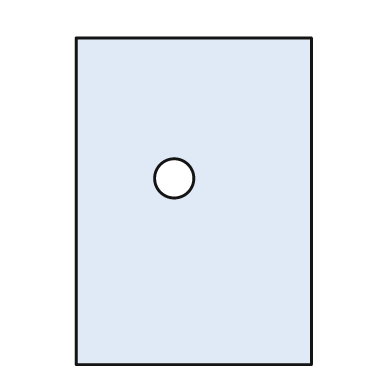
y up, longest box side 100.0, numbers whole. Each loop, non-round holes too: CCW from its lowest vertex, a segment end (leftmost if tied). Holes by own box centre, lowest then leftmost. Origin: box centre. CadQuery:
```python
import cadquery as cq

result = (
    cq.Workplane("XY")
    .moveTo(-36.0, -50.0)
    .lineTo(36.0, -50.0)
    .lineTo(36.0, 50.0)
    .lineTo(-36.0, 50.0)
    .close()
    .moveTo(-6.0, 7.0)
    .circle(6.0)
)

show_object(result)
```